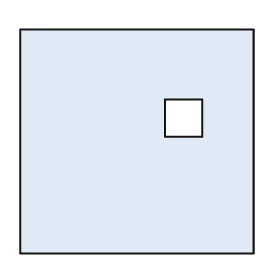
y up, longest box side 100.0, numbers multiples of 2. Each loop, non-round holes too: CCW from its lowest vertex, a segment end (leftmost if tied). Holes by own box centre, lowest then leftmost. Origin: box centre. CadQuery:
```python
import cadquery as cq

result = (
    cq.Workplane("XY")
    .moveTo(-50.0, -48.0)
    .lineTo(50.0, -48.0)
    .lineTo(50.0, 48.0)
    .lineTo(-50.0, 48.0)
    .close()
    .moveTo(12.0, 2.0)
    .lineTo(28.0, 2.0)
    .lineTo(28.0, 18.0)
    .lineTo(12.0, 18.0)
    .close()
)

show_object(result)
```